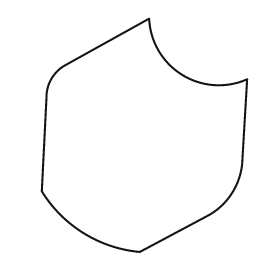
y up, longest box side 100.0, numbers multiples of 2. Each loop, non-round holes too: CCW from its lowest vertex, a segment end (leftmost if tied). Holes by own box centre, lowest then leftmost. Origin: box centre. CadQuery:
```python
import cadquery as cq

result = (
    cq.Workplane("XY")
    .moveTo(-2.0, -50.0)
    .lineTo(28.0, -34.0)
    .threePointArc((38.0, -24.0), (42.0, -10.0))
    .lineTo(44.0, 24.0)
    .threePointArc((16.0, 26.0), (2.0, 50.0))
    .lineTo(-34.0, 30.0)
    .threePointArc((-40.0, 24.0), (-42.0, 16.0))
    .lineTo(-44.0, -24.0)
    .threePointArc((-26.0, -42.0), (-2.0, -50.0))
    .close()
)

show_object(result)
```